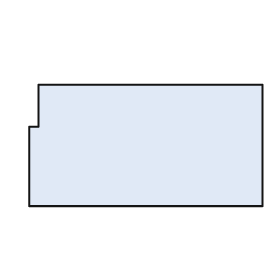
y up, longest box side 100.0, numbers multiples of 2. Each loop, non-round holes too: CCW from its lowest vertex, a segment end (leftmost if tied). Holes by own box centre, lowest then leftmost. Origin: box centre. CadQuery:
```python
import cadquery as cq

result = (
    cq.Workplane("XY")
    .moveTo(-50.0, -26.0)
    .lineTo(50.0, -26.0)
    .lineTo(50.0, 26.0)
    .lineTo(-46.0, 26.0)
    .lineTo(-46.0, 8.0)
    .lineTo(-50.0, 8.0)
    .close()
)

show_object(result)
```